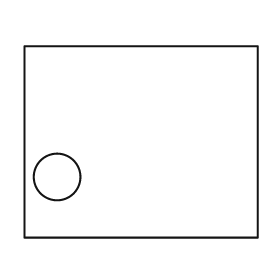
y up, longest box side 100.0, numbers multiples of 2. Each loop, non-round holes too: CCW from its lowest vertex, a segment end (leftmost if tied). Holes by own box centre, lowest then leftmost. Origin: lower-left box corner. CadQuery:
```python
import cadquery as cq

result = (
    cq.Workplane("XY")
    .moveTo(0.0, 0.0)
    .lineTo(100.0, 0.0)
    .lineTo(100.0, 82.0)
    .lineTo(0.0, 82.0)
    .close()
    .moveTo(14.0, 26.0)
    .circle(10.0)
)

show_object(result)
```